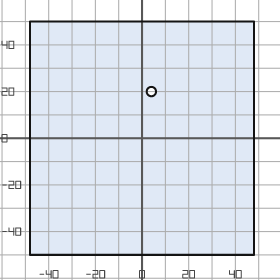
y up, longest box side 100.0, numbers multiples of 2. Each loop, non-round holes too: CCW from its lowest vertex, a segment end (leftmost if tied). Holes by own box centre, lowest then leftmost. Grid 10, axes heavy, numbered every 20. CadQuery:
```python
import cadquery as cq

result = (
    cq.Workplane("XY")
    .moveTo(-48.0, -50.0)
    .lineTo(48.0, -50.0)
    .lineTo(48.0, 50.0)
    .lineTo(-48.0, 50.0)
    .close()
    .moveTo(4.0, 20.0)
    .circle(2.0)
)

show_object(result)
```